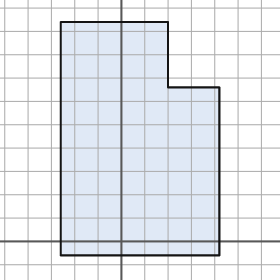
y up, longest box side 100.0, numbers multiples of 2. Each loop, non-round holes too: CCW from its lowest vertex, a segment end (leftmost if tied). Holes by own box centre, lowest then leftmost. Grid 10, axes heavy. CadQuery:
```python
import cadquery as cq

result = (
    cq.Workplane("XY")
    .moveTo(-26.0, -6.0)
    .lineTo(42.0, -6.0)
    .lineTo(42.0, 66.0)
    .lineTo(20.0, 66.0)
    .lineTo(20.0, 94.0)
    .lineTo(-26.0, 94.0)
    .close()
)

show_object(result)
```